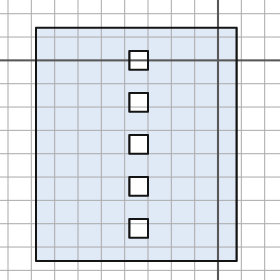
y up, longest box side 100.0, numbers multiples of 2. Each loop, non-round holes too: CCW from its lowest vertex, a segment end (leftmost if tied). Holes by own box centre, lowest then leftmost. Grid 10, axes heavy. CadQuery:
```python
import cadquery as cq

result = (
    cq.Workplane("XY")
    .moveTo(-78.0, -86.0)
    .lineTo(8.0, -86.0)
    .lineTo(8.0, 14.0)
    .lineTo(-78.0, 14.0)
    .close()
    .moveTo(-38.0, -76.0)
    .lineTo(-30.0, -76.0)
    .lineTo(-30.0, -68.0)
    .lineTo(-38.0, -68.0)
    .close()
    .moveTo(-38.0, -58.0)
    .lineTo(-30.0, -58.0)
    .lineTo(-30.0, -50.0)
    .lineTo(-38.0, -50.0)
    .close()
    .moveTo(-38.0, -40.0)
    .lineTo(-30.0, -40.0)
    .lineTo(-30.0, -32.0)
    .lineTo(-38.0, -32.0)
    .close()
    .moveTo(-38.0, -22.0)
    .lineTo(-30.0, -22.0)
    .lineTo(-30.0, -14.0)
    .lineTo(-38.0, -14.0)
    .close()
    .moveTo(-38.0, -4.0)
    .lineTo(-30.0, -4.0)
    .lineTo(-30.0, 4.0)
    .lineTo(-38.0, 4.0)
    .close()
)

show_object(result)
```